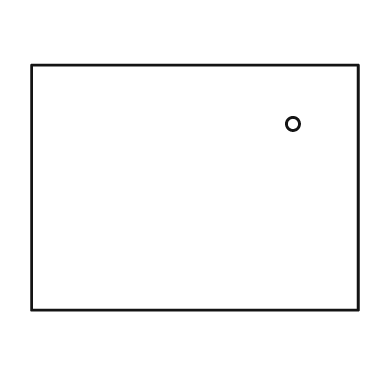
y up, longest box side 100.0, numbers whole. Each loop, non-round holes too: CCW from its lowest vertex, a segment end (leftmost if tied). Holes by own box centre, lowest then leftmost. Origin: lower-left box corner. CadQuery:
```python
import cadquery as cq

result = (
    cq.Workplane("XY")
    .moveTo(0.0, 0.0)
    .lineTo(100.0, 0.0)
    .lineTo(100.0, 75.0)
    .lineTo(0.0, 75.0)
    .close()
    .moveTo(80.0, 57.0)
    .circle(2.0)
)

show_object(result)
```